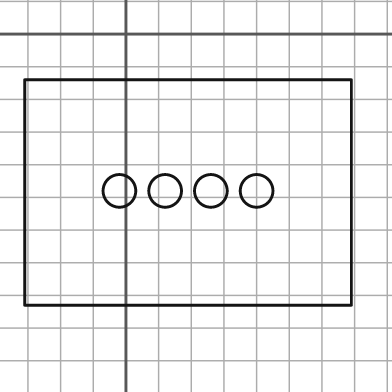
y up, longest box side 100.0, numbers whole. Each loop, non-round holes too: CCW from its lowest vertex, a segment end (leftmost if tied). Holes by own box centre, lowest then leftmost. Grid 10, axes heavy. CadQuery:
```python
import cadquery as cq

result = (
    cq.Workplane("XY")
    .moveTo(-31.0, -83.0)
    .lineTo(69.0, -83.0)
    .lineTo(69.0, -14.0)
    .lineTo(-31.0, -14.0)
    .close()
    .moveTo(-2.0, -48.0)
    .circle(5.0)
    .moveTo(12.0, -48.0)
    .circle(5.0)
    .moveTo(26.0, -48.0)
    .circle(5.0)
    .moveTo(40.0, -48.0)
    .circle(5.0)
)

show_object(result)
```